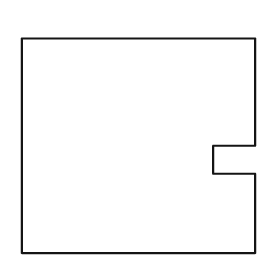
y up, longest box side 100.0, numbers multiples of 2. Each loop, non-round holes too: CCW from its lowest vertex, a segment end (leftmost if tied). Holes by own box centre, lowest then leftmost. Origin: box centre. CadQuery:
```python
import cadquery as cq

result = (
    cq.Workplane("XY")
    .moveTo(-50.0, -46.0)
    .lineTo(50.0, -46.0)
    .lineTo(50.0, -12.0)
    .lineTo(32.0, -12.0)
    .lineTo(32.0, 0.0)
    .lineTo(50.0, 0.0)
    .lineTo(50.0, 46.0)
    .lineTo(-50.0, 46.0)
    .close()
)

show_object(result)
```